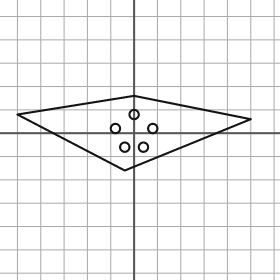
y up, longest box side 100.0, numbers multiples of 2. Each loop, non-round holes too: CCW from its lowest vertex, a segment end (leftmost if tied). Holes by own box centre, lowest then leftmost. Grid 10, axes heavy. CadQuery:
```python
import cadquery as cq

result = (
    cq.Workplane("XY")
    .moveTo(-4.0, -16.0)
    .lineTo(50.0, 6.0)
    .lineTo(0.0, 16.0)
    .lineTo(-50.0, 8.0)
    .close()
    .moveTo(-4.0, -6.0)
    .circle(2.0)
    .moveTo(4.0, -6.0)
    .circle(2.0)
    .moveTo(-8.0, 2.0)
    .circle(2.0)
    .moveTo(8.0, 2.0)
    .circle(2.0)
    .moveTo(0.0, 8.0)
    .circle(2.0)
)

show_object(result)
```